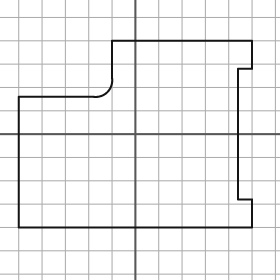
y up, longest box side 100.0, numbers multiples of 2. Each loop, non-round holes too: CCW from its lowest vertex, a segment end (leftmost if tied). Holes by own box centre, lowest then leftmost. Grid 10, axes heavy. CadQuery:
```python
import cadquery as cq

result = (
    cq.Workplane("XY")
    .moveTo(-50.0, -40.0)
    .lineTo(50.0, -40.0)
    .lineTo(50.0, -28.0)
    .lineTo(44.0, -28.0)
    .lineTo(44.0, 28.0)
    .lineTo(50.0, 28.0)
    .lineTo(50.0, 40.0)
    .lineTo(-10.0, 40.0)
    .lineTo(-10.0, 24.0)
    .threePointArc((-12.0, 18.0), (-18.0, 16.0))
    .lineTo(-50.0, 16.0)
    .close()
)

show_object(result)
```